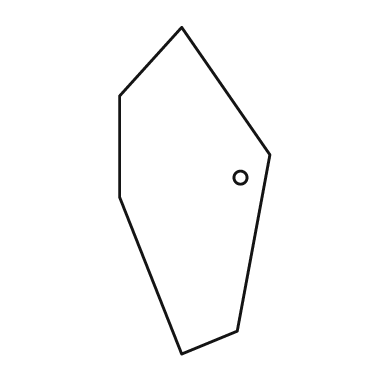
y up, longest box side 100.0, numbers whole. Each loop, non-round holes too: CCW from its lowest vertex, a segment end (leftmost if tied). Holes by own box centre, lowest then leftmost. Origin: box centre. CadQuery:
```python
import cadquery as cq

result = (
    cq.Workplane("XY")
    .moveTo(-4.0, -50.0)
    .lineTo(13.0, -43.0)
    .lineTo(23.0, 11.0)
    .lineTo(-4.0, 50.0)
    .lineTo(-23.0, 29.0)
    .lineTo(-23.0, -2.0)
    .close()
    .moveTo(14.0, 4.0)
    .circle(2.0)
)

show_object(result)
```